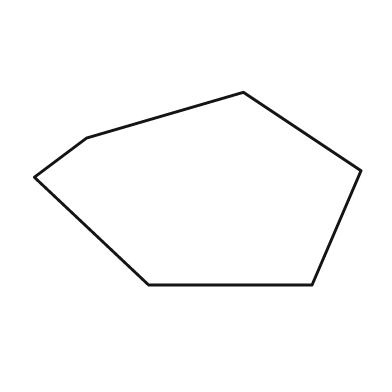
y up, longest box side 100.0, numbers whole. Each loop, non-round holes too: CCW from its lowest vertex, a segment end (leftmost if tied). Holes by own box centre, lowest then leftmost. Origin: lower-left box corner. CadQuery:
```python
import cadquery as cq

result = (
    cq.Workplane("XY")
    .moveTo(35.0, 0.0)
    .lineTo(85.0, 0.0)
    .lineTo(100.0, 35.0)
    .lineTo(64.0, 59.0)
    .lineTo(16.0, 45.0)
    .lineTo(0.0, 33.0)
    .close()
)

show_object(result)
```